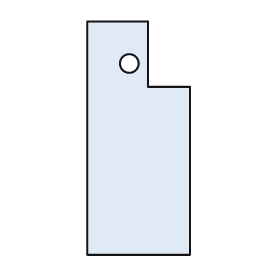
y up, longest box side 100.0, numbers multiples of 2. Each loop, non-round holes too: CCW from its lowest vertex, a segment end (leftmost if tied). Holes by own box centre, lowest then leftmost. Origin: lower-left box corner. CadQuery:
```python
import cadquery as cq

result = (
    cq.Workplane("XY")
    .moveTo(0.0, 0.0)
    .lineTo(44.0, 0.0)
    .lineTo(44.0, 72.0)
    .lineTo(26.0, 72.0)
    .lineTo(26.0, 100.0)
    .lineTo(0.0, 100.0)
    .close()
    .moveTo(18.0, 82.0)
    .circle(4.0)
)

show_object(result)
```